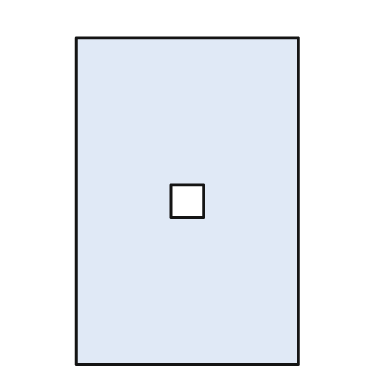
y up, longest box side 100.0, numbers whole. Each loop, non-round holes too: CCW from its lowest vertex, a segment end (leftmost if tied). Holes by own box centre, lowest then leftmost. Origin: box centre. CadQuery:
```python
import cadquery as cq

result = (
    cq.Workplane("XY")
    .moveTo(-34.0, -50.0)
    .lineTo(34.0, -50.0)
    .lineTo(34.0, 50.0)
    .lineTo(-34.0, 50.0)
    .close()
    .moveTo(-5.0, -5.0)
    .lineTo(5.0, -5.0)
    .lineTo(5.0, 5.0)
    .lineTo(-5.0, 5.0)
    .close()
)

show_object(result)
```